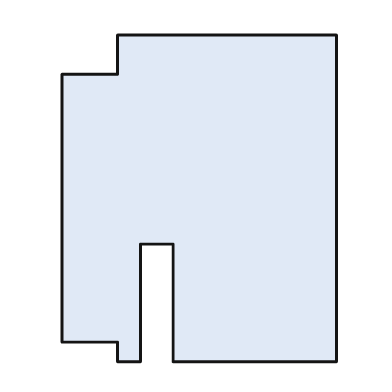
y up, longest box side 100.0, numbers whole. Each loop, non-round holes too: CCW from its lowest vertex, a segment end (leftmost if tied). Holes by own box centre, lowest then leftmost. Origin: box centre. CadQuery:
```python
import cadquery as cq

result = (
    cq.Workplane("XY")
    .moveTo(-25.0, -50.0)
    .lineTo(-18.0, -50.0)
    .lineTo(-18.0, -14.0)
    .lineTo(-8.0, -14.0)
    .lineTo(-8.0, -50.0)
    .lineTo(42.0, -50.0)
    .lineTo(42.0, 50.0)
    .lineTo(-25.0, 50.0)
    .lineTo(-25.0, 38.0)
    .lineTo(-42.0, 38.0)
    .lineTo(-42.0, -44.0)
    .lineTo(-25.0, -44.0)
    .close()
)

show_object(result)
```